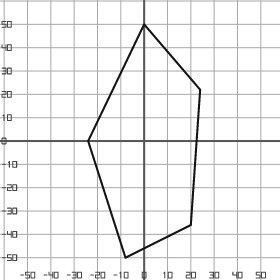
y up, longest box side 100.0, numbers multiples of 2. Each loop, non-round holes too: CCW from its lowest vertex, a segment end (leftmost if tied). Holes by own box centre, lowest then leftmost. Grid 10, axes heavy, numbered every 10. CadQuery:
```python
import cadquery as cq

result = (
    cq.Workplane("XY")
    .moveTo(-8.0, -50.0)
    .lineTo(20.0, -36.0)
    .lineTo(24.0, 22.0)
    .lineTo(0.0, 50.0)
    .lineTo(-24.0, 0.0)
    .close()
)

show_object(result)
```